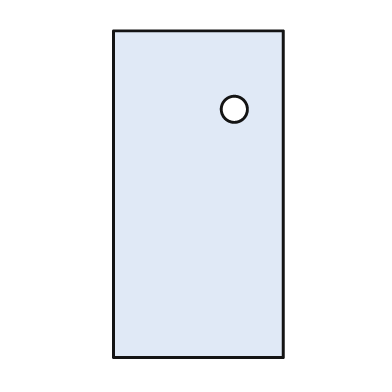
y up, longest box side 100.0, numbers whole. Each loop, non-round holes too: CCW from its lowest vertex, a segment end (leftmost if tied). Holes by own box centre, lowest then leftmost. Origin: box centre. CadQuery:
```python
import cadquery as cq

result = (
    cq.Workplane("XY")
    .moveTo(-26.0, -50.0)
    .lineTo(26.0, -50.0)
    .lineTo(26.0, 50.0)
    .lineTo(-26.0, 50.0)
    .close()
    .moveTo(11.0, 26.0)
    .circle(4.0)
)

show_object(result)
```